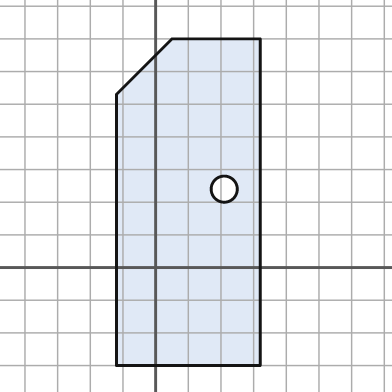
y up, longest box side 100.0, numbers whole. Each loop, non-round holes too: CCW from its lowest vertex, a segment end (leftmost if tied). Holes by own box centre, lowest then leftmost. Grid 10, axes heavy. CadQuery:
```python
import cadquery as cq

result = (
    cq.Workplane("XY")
    .moveTo(-12.0, -30.0)
    .lineTo(32.0, -30.0)
    .lineTo(32.0, 70.0)
    .lineTo(5.0, 70.0)
    .lineTo(-12.0, 53.0)
    .close()
    .moveTo(21.0, 24.0)
    .circle(4.0)
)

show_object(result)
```